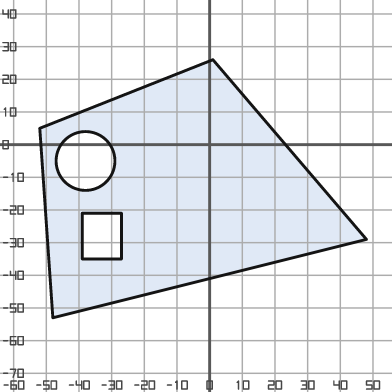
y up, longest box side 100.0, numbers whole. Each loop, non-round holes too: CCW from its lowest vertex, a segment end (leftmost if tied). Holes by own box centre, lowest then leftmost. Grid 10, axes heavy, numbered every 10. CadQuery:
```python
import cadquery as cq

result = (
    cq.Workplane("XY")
    .moveTo(-48.0, -53.0)
    .lineTo(48.0, -29.0)
    .lineTo(1.0, 26.0)
    .lineTo(-52.0, 5.0)
    .close()
    .moveTo(-39.0, -35.0)
    .lineTo(-27.0, -35.0)
    .lineTo(-27.0, -21.0)
    .lineTo(-39.0, -21.0)
    .close()
    .moveTo(-38.0, -5.0)
    .circle(9.0)
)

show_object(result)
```